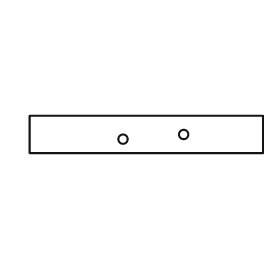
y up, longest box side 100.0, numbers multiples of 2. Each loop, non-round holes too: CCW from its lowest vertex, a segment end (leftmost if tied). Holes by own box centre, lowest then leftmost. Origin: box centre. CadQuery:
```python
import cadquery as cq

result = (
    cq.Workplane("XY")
    .moveTo(-50.0, -8.0)
    .lineTo(50.0, -8.0)
    .lineTo(50.0, 8.0)
    .lineTo(-50.0, 8.0)
    .close()
    .moveTo(-10.0, -2.0)
    .circle(2.0)
    .moveTo(16.0, 0.0)
    .circle(2.0)
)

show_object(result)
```